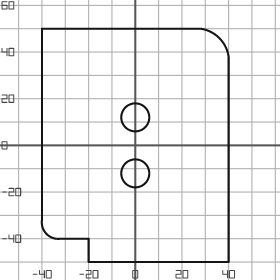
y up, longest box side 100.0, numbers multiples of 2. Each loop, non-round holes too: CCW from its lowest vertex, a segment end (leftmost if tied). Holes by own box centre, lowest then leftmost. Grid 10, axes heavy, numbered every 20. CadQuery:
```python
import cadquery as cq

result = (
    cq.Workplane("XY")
    .moveTo(-20.0, -50.0)
    .lineTo(40.0, -50.0)
    .lineTo(40.0, 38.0)
    .threePointArc((36.0, 46.0), (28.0, 50.0))
    .lineTo(-40.0, 50.0)
    .lineTo(-40.0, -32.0)
    .threePointArc((-38.0, -38.0), (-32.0, -40.0))
    .lineTo(-20.0, -40.0)
    .close()
    .moveTo(0.0, -12.0)
    .circle(6.0)
    .moveTo(0.0, 12.0)
    .circle(6.0)
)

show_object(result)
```